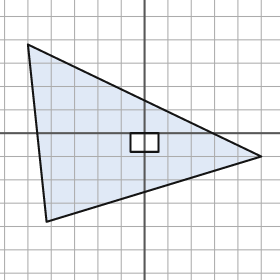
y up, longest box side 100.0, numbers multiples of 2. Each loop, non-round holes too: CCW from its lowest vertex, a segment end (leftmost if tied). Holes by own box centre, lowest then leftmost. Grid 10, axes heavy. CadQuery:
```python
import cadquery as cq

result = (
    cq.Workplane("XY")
    .moveTo(-42.0, -38.0)
    .lineTo(50.0, -10.0)
    .lineTo(-50.0, 38.0)
    .close()
    .moveTo(-6.0, -8.0)
    .lineTo(6.0, -8.0)
    .lineTo(6.0, 0.0)
    .lineTo(-6.0, 0.0)
    .close()
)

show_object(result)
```